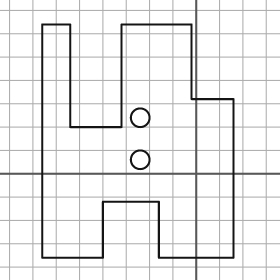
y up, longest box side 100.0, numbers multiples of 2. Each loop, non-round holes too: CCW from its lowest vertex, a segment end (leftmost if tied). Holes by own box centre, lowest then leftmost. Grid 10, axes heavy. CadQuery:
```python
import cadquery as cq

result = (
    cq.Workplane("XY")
    .moveTo(-66.0, -36.0)
    .lineTo(-40.0, -36.0)
    .lineTo(-40.0, -12.0)
    .lineTo(-16.0, -12.0)
    .lineTo(-16.0, -36.0)
    .lineTo(16.0, -36.0)
    .lineTo(16.0, 32.0)
    .lineTo(-2.0, 32.0)
    .lineTo(-2.0, 64.0)
    .lineTo(-32.0, 64.0)
    .lineTo(-32.0, 20.0)
    .lineTo(-54.0, 20.0)
    .lineTo(-54.0, 64.0)
    .lineTo(-66.0, 64.0)
    .close()
    .moveTo(-24.0, 6.0)
    .circle(4.0)
    .moveTo(-24.0, 24.0)
    .circle(4.0)
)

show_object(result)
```